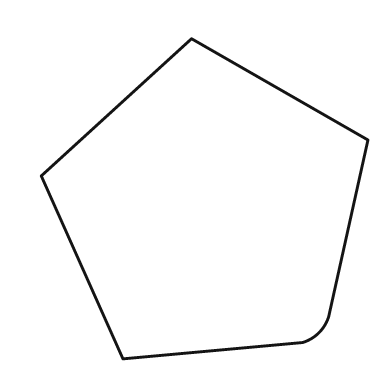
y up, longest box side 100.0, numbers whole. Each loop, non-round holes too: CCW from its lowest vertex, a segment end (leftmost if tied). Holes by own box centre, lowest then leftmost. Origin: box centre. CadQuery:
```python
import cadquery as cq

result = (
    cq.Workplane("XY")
    .moveTo(-25.0, -49.0)
    .lineTo(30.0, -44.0)
    .threePointArc((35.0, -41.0), (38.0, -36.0))
    .lineTo(50.0, 18.0)
    .lineTo(-4.0, 49.0)
    .lineTo(-50.0, 7.0)
    .close()
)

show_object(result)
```